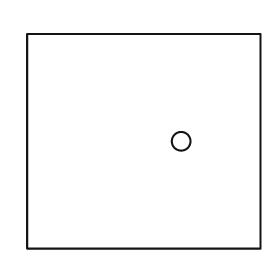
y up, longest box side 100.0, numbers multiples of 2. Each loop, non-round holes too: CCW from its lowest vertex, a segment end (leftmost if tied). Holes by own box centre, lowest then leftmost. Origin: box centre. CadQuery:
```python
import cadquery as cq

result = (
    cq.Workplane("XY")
    .moveTo(-50.0, -46.0)
    .lineTo(50.0, -46.0)
    .lineTo(50.0, 46.0)
    .lineTo(-50.0, 46.0)
    .close()
    .moveTo(16.0, 0.0)
    .circle(4.0)
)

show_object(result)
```